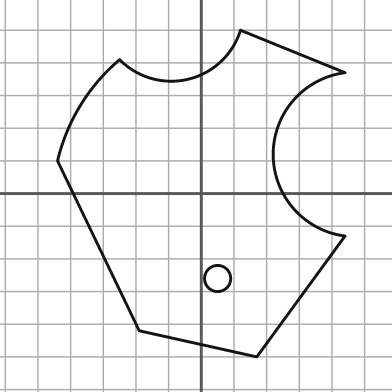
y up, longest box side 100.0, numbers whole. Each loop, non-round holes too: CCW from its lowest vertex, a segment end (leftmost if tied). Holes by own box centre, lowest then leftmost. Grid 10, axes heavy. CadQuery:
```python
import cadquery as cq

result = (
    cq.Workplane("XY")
    .moveTo(17.0, -50.0)
    .lineTo(44.0, -13.0)
    .threePointArc((22.0, 12.0), (44.0, 37.0))
    .lineTo(12.0, 50.0)
    .threePointArc((-4.0, 35.0), (-25.0, 41.0))
    .threePointArc((-37.0, 27.0), (-44.0, 10.0))
    .lineTo(-19.0, -42.0)
    .close()
    .moveTo(5.0, -26.0)
    .circle(4.0)
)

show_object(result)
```